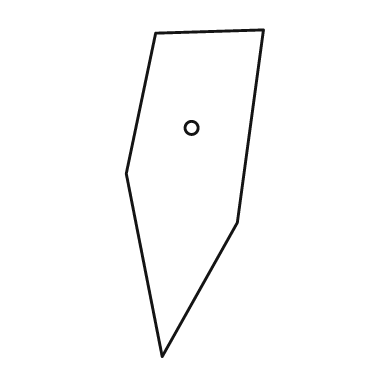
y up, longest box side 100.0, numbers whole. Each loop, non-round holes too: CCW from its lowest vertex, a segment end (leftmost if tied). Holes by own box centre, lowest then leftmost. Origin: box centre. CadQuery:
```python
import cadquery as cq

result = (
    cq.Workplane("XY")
    .moveTo(-10.0, -50.0)
    .lineTo(13.0, -9.0)
    .lineTo(21.0, 50.0)
    .lineTo(-12.0, 49.0)
    .lineTo(-21.0, 6.0)
    .close()
    .moveTo(-1.0, 20.0)
    .circle(2.0)
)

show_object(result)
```